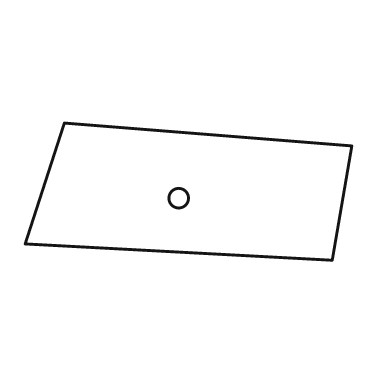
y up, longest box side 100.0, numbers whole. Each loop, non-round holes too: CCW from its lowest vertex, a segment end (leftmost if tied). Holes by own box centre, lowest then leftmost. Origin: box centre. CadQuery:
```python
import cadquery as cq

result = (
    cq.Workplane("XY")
    .moveTo(44.0, -21.0)
    .lineTo(50.0, 14.0)
    .lineTo(-38.0, 21.0)
    .lineTo(-50.0, -16.0)
    .close()
    .moveTo(-3.0, -2.0)
    .circle(3.0)
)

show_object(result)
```